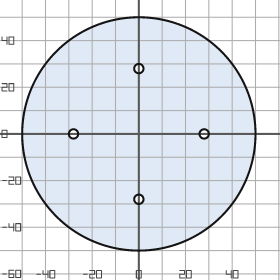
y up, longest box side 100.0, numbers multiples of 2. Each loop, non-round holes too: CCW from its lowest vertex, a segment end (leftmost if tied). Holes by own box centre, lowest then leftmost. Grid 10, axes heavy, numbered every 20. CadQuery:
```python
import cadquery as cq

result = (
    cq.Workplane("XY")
    .moveTo(0.0, 0.0)
    .circle(50.0)
    .moveTo(0.0, -28.0)
    .circle(2.0)
    .moveTo(-28.0, 0.0)
    .circle(2.0)
    .moveTo(28.0, 0.0)
    .circle(2.0)
    .moveTo(0.0, 28.0)
    .circle(2.0)
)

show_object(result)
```